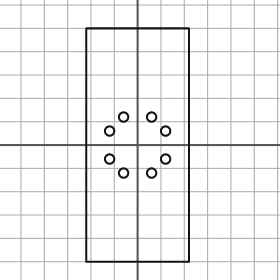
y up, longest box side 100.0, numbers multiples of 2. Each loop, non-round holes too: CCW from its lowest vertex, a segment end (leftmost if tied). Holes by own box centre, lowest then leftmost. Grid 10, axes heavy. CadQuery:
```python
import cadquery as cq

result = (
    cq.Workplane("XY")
    .moveTo(-22.0, -50.0)
    .lineTo(22.0, -50.0)
    .lineTo(22.0, 50.0)
    .lineTo(-22.0, 50.0)
    .close()
    .moveTo(-6.0, -12.0)
    .circle(2.0)
    .moveTo(6.0, -12.0)
    .circle(2.0)
    .moveTo(-12.0, -6.0)
    .circle(2.0)
    .moveTo(12.0, -6.0)
    .circle(2.0)
    .moveTo(-12.0, 6.0)
    .circle(2.0)
    .moveTo(12.0, 6.0)
    .circle(2.0)
    .moveTo(-6.0, 12.0)
    .circle(2.0)
    .moveTo(6.0, 12.0)
    .circle(2.0)
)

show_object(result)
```